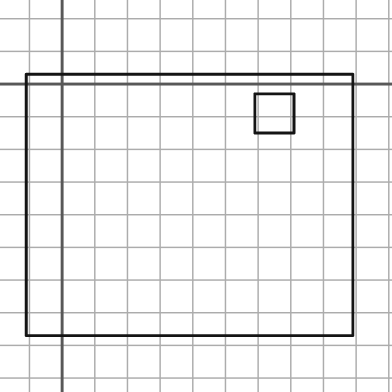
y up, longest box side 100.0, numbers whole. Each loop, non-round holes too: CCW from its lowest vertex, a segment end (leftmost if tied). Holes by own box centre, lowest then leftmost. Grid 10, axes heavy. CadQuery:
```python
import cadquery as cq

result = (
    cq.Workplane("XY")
    .moveTo(-11.0, -77.0)
    .lineTo(89.0, -77.0)
    .lineTo(89.0, 3.0)
    .lineTo(-11.0, 3.0)
    .close()
    .moveTo(59.0, -15.0)
    .lineTo(71.0, -15.0)
    .lineTo(71.0, -3.0)
    .lineTo(59.0, -3.0)
    .close()
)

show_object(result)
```